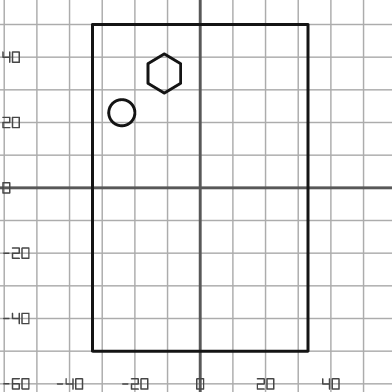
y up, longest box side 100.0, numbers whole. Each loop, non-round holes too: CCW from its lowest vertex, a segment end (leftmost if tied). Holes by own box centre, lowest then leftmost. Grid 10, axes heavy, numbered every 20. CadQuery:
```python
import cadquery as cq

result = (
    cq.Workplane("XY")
    .moveTo(-33.0, -50.0)
    .lineTo(33.0, -50.0)
    .lineTo(33.0, 50.0)
    .lineTo(-33.0, 50.0)
    .close()
    .moveTo(-24.0, 23.0)
    .circle(4.0)
    .moveTo(-11.0, 29.0)
    .lineTo(-6.0, 32.0)
    .lineTo(-6.0, 38.0)
    .lineTo(-11.0, 41.0)
    .lineTo(-16.0, 38.0)
    .lineTo(-16.0, 32.0)
    .close()
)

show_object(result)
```